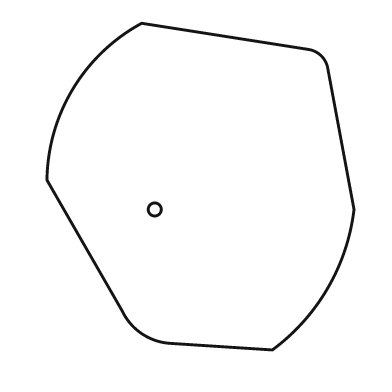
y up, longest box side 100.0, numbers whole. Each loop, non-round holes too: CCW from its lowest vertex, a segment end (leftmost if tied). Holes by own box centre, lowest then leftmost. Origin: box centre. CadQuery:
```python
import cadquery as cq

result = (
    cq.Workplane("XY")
    .moveTo(22.0, -50.0)
    .threePointArc((39.0, -31.0), (47.0, -7.0))
    .lineTo(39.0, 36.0)
    .threePointArc((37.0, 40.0), (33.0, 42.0))
    .lineTo(-18.0, 50.0)
    .threePointArc((-39.0, 30.0), (-47.0, 2.0))
    .lineTo(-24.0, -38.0)
    .threePointArc((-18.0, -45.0), (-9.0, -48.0))
    .close()
    .moveTo(-14.0, -7.0)
    .circle(2.0)
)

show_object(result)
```